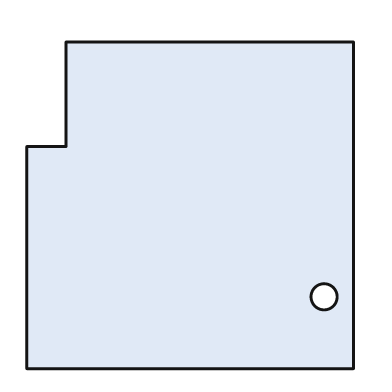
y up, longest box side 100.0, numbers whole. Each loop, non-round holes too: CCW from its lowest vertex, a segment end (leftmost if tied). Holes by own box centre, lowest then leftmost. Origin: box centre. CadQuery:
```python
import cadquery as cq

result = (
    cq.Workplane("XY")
    .moveTo(-50.0, -50.0)
    .lineTo(50.0, -50.0)
    .lineTo(50.0, 50.0)
    .lineTo(-38.0, 50.0)
    .lineTo(-38.0, 18.0)
    .lineTo(-50.0, 18.0)
    .close()
    .moveTo(41.0, -28.0)
    .circle(4.0)
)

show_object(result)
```